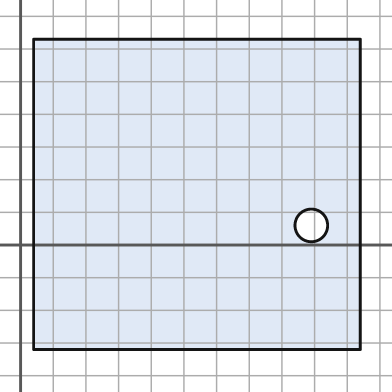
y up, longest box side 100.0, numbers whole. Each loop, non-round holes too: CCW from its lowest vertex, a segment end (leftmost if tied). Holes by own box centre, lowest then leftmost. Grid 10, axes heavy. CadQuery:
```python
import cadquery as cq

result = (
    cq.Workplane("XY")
    .moveTo(4.0, -32.0)
    .lineTo(104.0, -32.0)
    .lineTo(104.0, 63.0)
    .lineTo(4.0, 63.0)
    .close()
    .moveTo(89.0, 6.0)
    .circle(5.0)
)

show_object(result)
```